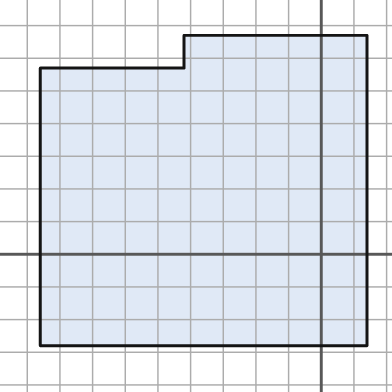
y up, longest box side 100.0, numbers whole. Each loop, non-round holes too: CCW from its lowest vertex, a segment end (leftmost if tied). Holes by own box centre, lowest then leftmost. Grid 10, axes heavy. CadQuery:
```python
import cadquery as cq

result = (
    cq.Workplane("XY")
    .moveTo(-86.0, -28.0)
    .lineTo(14.0, -28.0)
    .lineTo(14.0, 67.0)
    .lineTo(-42.0, 67.0)
    .lineTo(-42.0, 57.0)
    .lineTo(-86.0, 57.0)
    .close()
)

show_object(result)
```